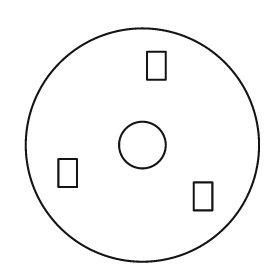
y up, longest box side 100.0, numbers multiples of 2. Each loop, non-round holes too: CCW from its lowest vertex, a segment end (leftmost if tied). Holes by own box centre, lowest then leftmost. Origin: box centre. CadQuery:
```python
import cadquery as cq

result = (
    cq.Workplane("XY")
    .moveTo(0.0, 0.0)
    .circle(50.0)
    .moveTo(22.0, -28.0)
    .lineTo(30.0, -28.0)
    .lineTo(30.0, -16.0)
    .lineTo(22.0, -16.0)
    .close()
    .moveTo(-36.0, -18.0)
    .lineTo(-28.0, -18.0)
    .lineTo(-28.0, -6.0)
    .lineTo(-36.0, -6.0)
    .close()
    .moveTo(0.0, 0.0)
    .circle(10.0)
    .moveTo(2.0, 28.0)
    .lineTo(10.0, 28.0)
    .lineTo(10.0, 40.0)
    .lineTo(2.0, 40.0)
    .close()
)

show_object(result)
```